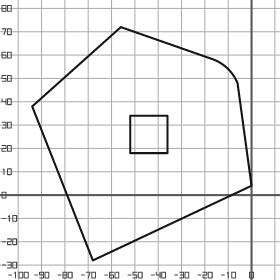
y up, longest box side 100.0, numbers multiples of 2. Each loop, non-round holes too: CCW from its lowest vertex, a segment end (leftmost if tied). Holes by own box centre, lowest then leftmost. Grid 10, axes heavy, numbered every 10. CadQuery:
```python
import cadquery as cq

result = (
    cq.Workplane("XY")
    .moveTo(-68.0, -28.0)
    .lineTo(0.0, 4.0)
    .lineTo(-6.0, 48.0)
    .threePointArc((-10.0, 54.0), (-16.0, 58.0))
    .lineTo(-56.0, 72.0)
    .lineTo(-94.0, 38.0)
    .close()
    .moveTo(-52.0, 18.0)
    .lineTo(-36.0, 18.0)
    .lineTo(-36.0, 34.0)
    .lineTo(-52.0, 34.0)
    .close()
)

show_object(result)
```